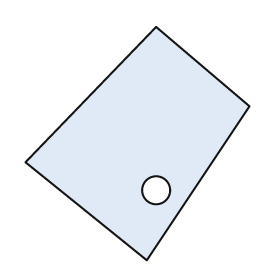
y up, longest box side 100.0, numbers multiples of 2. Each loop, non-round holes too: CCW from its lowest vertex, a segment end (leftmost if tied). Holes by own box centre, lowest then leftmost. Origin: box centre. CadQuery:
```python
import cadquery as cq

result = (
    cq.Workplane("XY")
    .moveTo(4.0, -50.0)
    .lineTo(48.0, 16.0)
    .lineTo(8.0, 50.0)
    .lineTo(-48.0, -8.0)
    .close()
    .moveTo(8.0, -20.0)
    .circle(6.0)
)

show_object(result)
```